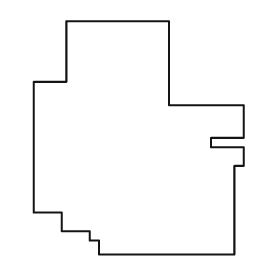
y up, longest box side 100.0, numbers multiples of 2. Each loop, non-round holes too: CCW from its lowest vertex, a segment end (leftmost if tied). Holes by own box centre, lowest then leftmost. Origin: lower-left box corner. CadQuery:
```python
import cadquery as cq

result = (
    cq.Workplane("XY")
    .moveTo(28.0, 0.0)
    .lineTo(86.0, 0.0)
    .lineTo(86.0, 38.0)
    .lineTo(90.0, 38.0)
    .lineTo(90.0, 46.0)
    .lineTo(76.0, 46.0)
    .lineTo(76.0, 50.0)
    .lineTo(90.0, 50.0)
    .lineTo(90.0, 64.0)
    .lineTo(58.0, 64.0)
    .lineTo(58.0, 100.0)
    .lineTo(14.0, 100.0)
    .lineTo(14.0, 74.0)
    .lineTo(0.0, 74.0)
    .lineTo(0.0, 18.0)
    .lineTo(12.0, 18.0)
    .lineTo(12.0, 10.0)
    .lineTo(24.0, 10.0)
    .lineTo(24.0, 6.0)
    .lineTo(28.0, 6.0)
    .close()
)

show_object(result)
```